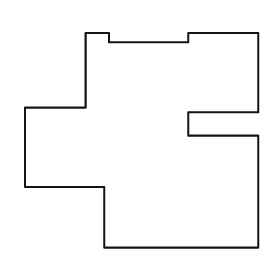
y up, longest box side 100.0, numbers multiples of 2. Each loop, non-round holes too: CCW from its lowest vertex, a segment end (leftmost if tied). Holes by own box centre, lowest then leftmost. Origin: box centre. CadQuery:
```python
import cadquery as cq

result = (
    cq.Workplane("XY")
    .moveTo(-16.0, -46.0)
    .lineTo(50.0, -46.0)
    .lineTo(50.0, 2.0)
    .lineTo(20.0, 2.0)
    .lineTo(20.0, 12.0)
    .lineTo(50.0, 12.0)
    .lineTo(50.0, 46.0)
    .lineTo(20.0, 46.0)
    .lineTo(20.0, 42.0)
    .lineTo(-14.0, 42.0)
    .lineTo(-14.0, 46.0)
    .lineTo(-24.0, 46.0)
    .lineTo(-24.0, 14.0)
    .lineTo(-50.0, 14.0)
    .lineTo(-50.0, -20.0)
    .lineTo(-16.0, -20.0)
    .close()
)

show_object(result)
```